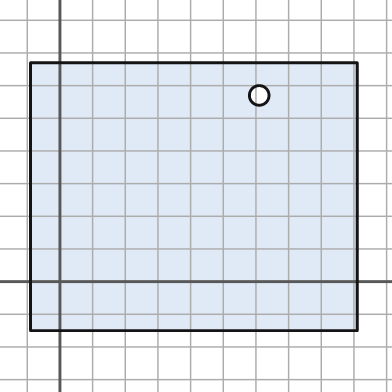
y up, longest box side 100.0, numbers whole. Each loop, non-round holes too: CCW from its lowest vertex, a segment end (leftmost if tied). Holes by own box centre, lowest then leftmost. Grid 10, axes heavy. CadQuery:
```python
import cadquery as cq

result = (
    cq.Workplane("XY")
    .moveTo(-9.0, -15.0)
    .lineTo(91.0, -15.0)
    .lineTo(91.0, 67.0)
    .lineTo(-9.0, 67.0)
    .close()
    .moveTo(61.0, 57.0)
    .circle(3.0)
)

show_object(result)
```